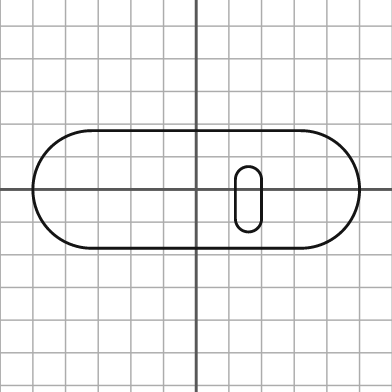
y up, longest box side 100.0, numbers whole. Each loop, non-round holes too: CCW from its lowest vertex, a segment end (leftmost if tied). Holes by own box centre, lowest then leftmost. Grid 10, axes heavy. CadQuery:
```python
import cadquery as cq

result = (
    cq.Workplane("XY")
    .moveTo(-32.0, -18.0)
    .lineTo(32.0, -18.0)
    .threePointArc((50.0, 0.0), (32.0, 18.0))
    .lineTo(-32.0, 18.0)
    .threePointArc((-50.0, 0.0), (-32.0, -18.0))
    .close()
    .moveTo(12.0, -9.0)
    .threePointArc((16.0, -13.0), (20.0, -9.0))
    .lineTo(20.0, 3.0)
    .threePointArc((16.0, 7.0), (12.0, 3.0))
    .close()
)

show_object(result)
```